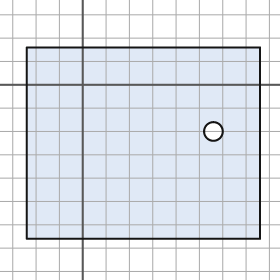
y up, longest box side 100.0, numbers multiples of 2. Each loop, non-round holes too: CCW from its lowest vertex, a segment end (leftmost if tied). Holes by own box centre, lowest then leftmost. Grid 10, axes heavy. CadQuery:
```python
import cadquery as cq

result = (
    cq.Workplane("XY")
    .moveTo(-24.0, -66.0)
    .lineTo(76.0, -66.0)
    .lineTo(76.0, 16.0)
    .lineTo(-24.0, 16.0)
    .close()
    .moveTo(56.0, -20.0)
    .circle(4.0)
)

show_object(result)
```